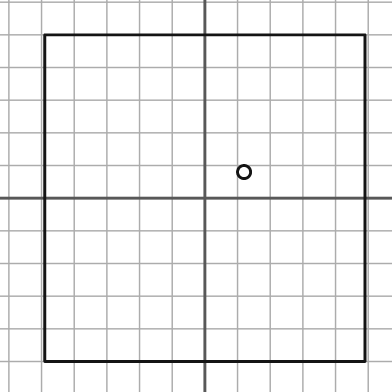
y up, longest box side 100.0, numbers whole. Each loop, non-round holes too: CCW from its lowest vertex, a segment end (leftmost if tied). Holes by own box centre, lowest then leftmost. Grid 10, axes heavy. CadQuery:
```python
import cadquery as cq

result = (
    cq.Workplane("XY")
    .moveTo(-49.0, -50.0)
    .lineTo(49.0, -50.0)
    .lineTo(49.0, 50.0)
    .lineTo(-49.0, 50.0)
    .close()
    .moveTo(12.0, 8.0)
    .circle(2.0)
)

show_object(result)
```